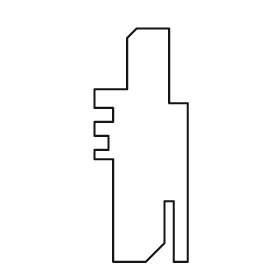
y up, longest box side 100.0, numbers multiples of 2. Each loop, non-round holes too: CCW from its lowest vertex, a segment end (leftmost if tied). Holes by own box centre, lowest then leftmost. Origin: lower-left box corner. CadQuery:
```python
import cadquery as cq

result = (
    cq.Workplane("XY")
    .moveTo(8.0, 0.0)
    .lineTo(22.0, 0.0)
    .lineTo(30.0, 8.0)
    .lineTo(30.0, 26.0)
    .lineTo(34.0, 26.0)
    .lineTo(34.0, 0.0)
    .lineTo(40.0, 0.0)
    .lineTo(40.0, 68.0)
    .lineTo(32.0, 68.0)
    .lineTo(32.0, 100.0)
    .lineTo(18.0, 100.0)
    .lineTo(14.0, 96.0)
    .lineTo(14.0, 74.0)
    .lineTo(0.0, 74.0)
    .lineTo(0.0, 66.0)
    .lineTo(8.0, 66.0)
    .lineTo(8.0, 60.0)
    .lineTo(0.0, 60.0)
    .lineTo(0.0, 54.0)
    .lineTo(6.0, 54.0)
    .lineTo(6.0, 48.0)
    .lineTo(0.0, 48.0)
    .lineTo(0.0, 44.0)
    .lineTo(8.0, 44.0)
    .close()
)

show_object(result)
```